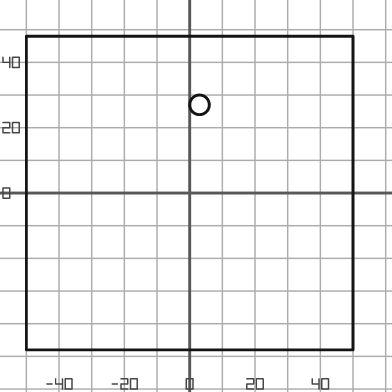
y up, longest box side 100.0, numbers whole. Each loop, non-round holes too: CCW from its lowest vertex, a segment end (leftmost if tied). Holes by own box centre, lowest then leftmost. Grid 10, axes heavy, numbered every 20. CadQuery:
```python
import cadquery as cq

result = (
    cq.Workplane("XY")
    .moveTo(-50.0, -48.0)
    .lineTo(50.0, -48.0)
    .lineTo(50.0, 48.0)
    .lineTo(-50.0, 48.0)
    .close()
    .moveTo(3.0, 27.0)
    .circle(3.0)
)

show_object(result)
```